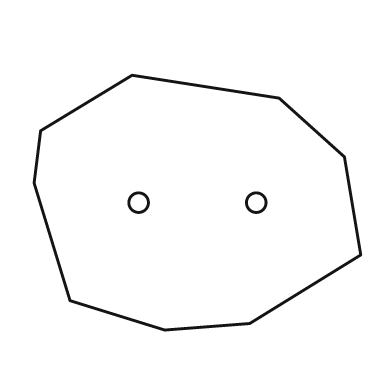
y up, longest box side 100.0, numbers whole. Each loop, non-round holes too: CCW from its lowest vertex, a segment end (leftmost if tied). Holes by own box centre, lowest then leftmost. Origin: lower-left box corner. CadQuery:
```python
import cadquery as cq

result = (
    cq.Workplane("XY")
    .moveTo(40.0, 0.0)
    .lineTo(66.0, 2.0)
    .lineTo(100.0, 23.0)
    .lineTo(95.0, 53.0)
    .lineTo(75.0, 71.0)
    .lineTo(30.0, 78.0)
    .lineTo(2.0, 61.0)
    .lineTo(0.0, 45.0)
    .lineTo(11.0, 9.0)
    .close()
    .moveTo(32.0, 39.0)
    .circle(3.0)
    .moveTo(68.0, 39.0)
    .circle(3.0)
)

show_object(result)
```